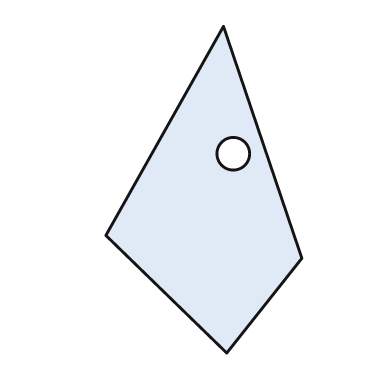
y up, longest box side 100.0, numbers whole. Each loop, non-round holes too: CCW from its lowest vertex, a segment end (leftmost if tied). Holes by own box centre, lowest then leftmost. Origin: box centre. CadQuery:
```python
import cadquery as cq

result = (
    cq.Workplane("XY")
    .moveTo(7.0, -50.0)
    .lineTo(30.0, -21.0)
    .lineTo(6.0, 50.0)
    .lineTo(-30.0, -14.0)
    .close()
    .moveTo(9.0, 11.0)
    .circle(5.0)
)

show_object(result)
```